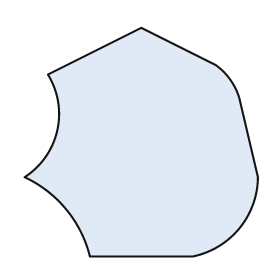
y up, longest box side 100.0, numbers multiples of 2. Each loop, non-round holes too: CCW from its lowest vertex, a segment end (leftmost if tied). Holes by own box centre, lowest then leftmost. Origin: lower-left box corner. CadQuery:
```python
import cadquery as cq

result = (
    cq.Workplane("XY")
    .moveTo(28.0, 0.0)
    .lineTo(72.0, 0.0)
    .threePointArc((92.0, 12.0), (100.0, 34.0))
    .lineTo(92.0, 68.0)
    .threePointArc((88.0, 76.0), (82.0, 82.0))
    .lineTo(50.0, 98.0)
    .lineTo(10.0, 78.0)
    .threePointArc((14.0, 54.0), (0.0, 34.0))
    .threePointArc((18.0, 20.0), (28.0, 0.0))
    .close()
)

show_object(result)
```